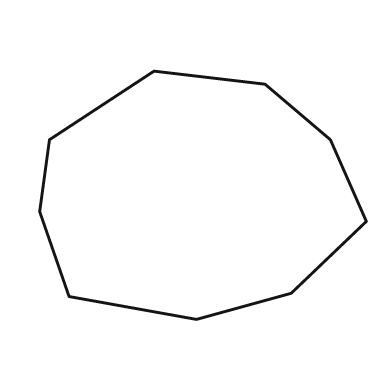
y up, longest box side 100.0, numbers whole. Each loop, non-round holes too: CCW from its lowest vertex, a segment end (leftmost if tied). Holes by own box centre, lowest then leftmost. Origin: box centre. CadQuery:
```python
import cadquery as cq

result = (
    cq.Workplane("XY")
    .moveTo(-2.0, -38.0)
    .lineTo(27.0, -30.0)
    .lineTo(50.0, -8.0)
    .lineTo(39.0, 17.0)
    .lineTo(19.0, 34.0)
    .lineTo(-15.0, 38.0)
    .lineTo(-47.0, 17.0)
    .lineTo(-50.0, -5.0)
    .lineTo(-41.0, -31.0)
    .close()
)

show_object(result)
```